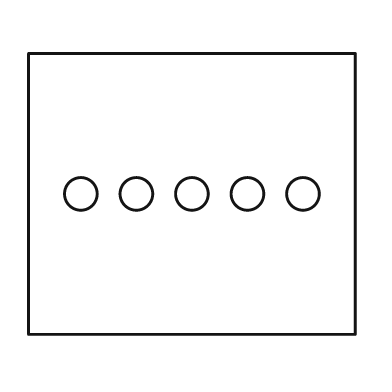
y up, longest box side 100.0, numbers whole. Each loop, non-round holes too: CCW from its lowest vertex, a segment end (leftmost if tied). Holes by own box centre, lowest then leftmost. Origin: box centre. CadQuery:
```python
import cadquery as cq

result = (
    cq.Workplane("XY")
    .moveTo(-50.0, -43.0)
    .lineTo(50.0, -43.0)
    .lineTo(50.0, 43.0)
    .lineTo(-50.0, 43.0)
    .close()
    .moveTo(-34.0, 0.0)
    .circle(5.0)
    .moveTo(-17.0, 0.0)
    .circle(5.0)
    .moveTo(0.0, 0.0)
    .circle(5.0)
    .moveTo(17.0, 0.0)
    .circle(5.0)
    .moveTo(34.0, 0.0)
    .circle(5.0)
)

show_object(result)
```